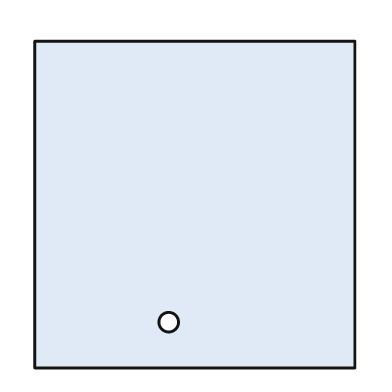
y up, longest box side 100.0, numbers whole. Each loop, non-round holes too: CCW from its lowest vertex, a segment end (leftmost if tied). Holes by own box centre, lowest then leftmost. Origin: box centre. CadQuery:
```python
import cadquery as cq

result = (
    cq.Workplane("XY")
    .moveTo(-49.0, -50.0)
    .lineTo(49.0, -50.0)
    .lineTo(49.0, 50.0)
    .lineTo(-49.0, 50.0)
    .close()
    .moveTo(-8.0, -36.0)
    .circle(3.0)
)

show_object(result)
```